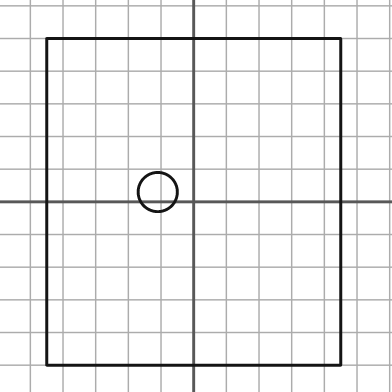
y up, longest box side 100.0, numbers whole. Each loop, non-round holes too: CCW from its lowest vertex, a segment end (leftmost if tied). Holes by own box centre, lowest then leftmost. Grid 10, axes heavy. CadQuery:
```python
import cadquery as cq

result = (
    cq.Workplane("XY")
    .moveTo(-45.0, -50.0)
    .lineTo(45.0, -50.0)
    .lineTo(45.0, 50.0)
    .lineTo(-45.0, 50.0)
    .close()
    .moveTo(-11.0, 3.0)
    .circle(6.0)
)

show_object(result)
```